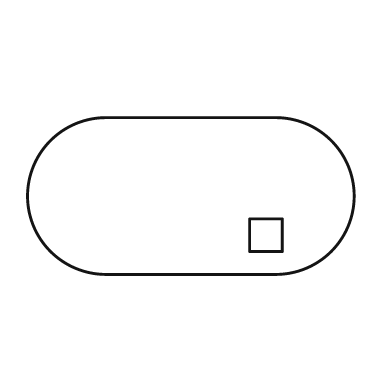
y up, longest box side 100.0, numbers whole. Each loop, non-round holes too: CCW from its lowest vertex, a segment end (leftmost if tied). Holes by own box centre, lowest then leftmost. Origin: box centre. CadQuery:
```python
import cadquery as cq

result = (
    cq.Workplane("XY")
    .moveTo(-26.0, -24.0)
    .lineTo(26.0, -24.0)
    .threePointArc((50.0, 0.0), (26.0, 24.0))
    .lineTo(-26.0, 24.0)
    .threePointArc((-50.0, 0.0), (-26.0, -24.0))
    .close()
    .moveTo(18.0, -17.0)
    .lineTo(28.0, -17.0)
    .lineTo(28.0, -7.0)
    .lineTo(18.0, -7.0)
    .close()
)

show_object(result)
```